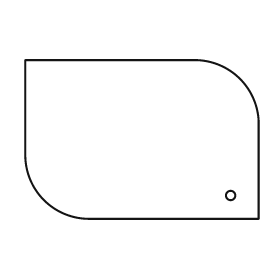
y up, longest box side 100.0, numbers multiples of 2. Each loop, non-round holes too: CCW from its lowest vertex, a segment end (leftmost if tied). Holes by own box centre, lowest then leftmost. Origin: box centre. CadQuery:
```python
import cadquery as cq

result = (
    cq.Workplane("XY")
    .moveTo(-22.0, -34.0)
    .lineTo(50.0, -34.0)
    .lineTo(50.0, 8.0)
    .threePointArc((42.0, 26.0), (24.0, 34.0))
    .lineTo(-50.0, 34.0)
    .lineTo(-50.0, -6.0)
    .threePointArc((-42.0, -26.0), (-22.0, -34.0))
    .close()
    .moveTo(38.0, -24.0)
    .circle(2.0)
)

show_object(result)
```